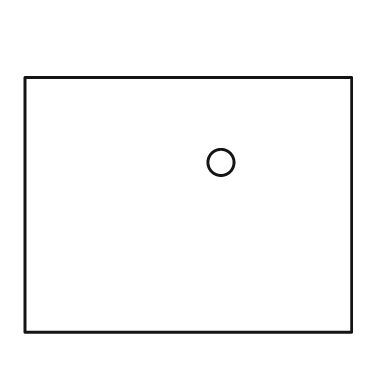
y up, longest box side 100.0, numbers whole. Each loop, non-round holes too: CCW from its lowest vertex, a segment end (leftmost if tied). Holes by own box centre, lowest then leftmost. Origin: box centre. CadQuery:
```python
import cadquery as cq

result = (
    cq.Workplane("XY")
    .moveTo(-50.0, -39.0)
    .lineTo(50.0, -39.0)
    .lineTo(50.0, 39.0)
    .lineTo(-50.0, 39.0)
    .close()
    .moveTo(10.0, 13.0)
    .circle(4.0)
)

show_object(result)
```